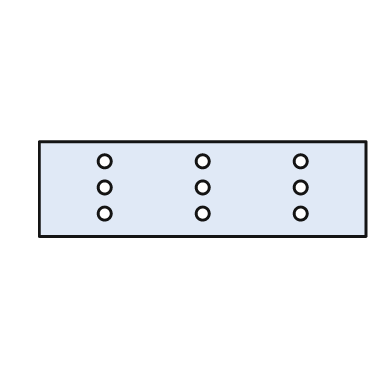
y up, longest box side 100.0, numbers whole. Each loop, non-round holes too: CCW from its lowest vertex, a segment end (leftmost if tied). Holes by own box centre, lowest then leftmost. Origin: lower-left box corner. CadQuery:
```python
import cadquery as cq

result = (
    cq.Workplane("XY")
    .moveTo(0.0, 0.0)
    .lineTo(100.0, 0.0)
    .lineTo(100.0, 29.0)
    .lineTo(0.0, 29.0)
    .close()
    .moveTo(20.0, 7.0)
    .circle(2.0)
    .moveTo(50.0, 7.0)
    .circle(2.0)
    .moveTo(80.0, 7.0)
    .circle(2.0)
    .moveTo(20.0, 15.0)
    .circle(2.0)
    .moveTo(50.0, 15.0)
    .circle(2.0)
    .moveTo(80.0, 15.0)
    .circle(2.0)
    .moveTo(20.0, 23.0)
    .circle(2.0)
    .moveTo(50.0, 23.0)
    .circle(2.0)
    .moveTo(80.0, 23.0)
    .circle(2.0)
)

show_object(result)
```